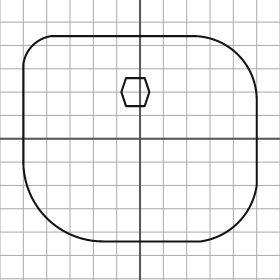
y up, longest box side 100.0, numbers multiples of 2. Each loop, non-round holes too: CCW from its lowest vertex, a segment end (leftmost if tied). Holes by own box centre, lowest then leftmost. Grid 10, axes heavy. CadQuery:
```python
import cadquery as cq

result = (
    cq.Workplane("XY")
    .moveTo(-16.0, -44.0)
    .lineTo(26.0, -44.0)
    .threePointArc((42.0, -36.0), (50.0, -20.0))
    .lineTo(50.0, 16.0)
    .threePointArc((42.0, 36.0), (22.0, 44.0))
    .lineTo(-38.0, 44.0)
    .threePointArc((-46.0, 40.0), (-50.0, 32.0))
    .lineTo(-50.0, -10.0)
    .threePointArc((-40.0, -34.0), (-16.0, -44.0))
    .close()
    .moveTo(-6.0, 14.0)
    .lineTo(2.0, 14.0)
    .lineTo(4.0, 20.0)
    .lineTo(2.0, 26.0)
    .lineTo(-6.0, 26.0)
    .lineTo(-8.0, 20.0)
    .close()
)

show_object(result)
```